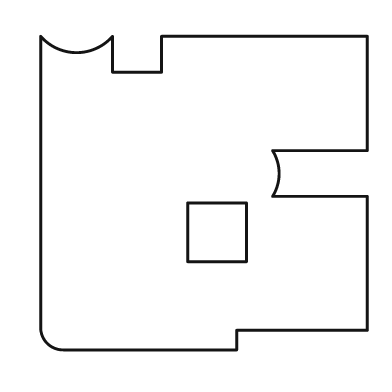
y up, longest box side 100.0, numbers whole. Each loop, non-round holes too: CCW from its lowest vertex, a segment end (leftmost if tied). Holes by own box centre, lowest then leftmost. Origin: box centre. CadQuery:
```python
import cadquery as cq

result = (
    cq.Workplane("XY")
    .moveTo(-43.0, -48.0)
    .lineTo(10.0, -48.0)
    .lineTo(10.0, -42.0)
    .lineTo(50.0, -42.0)
    .lineTo(50.0, -1.0)
    .lineTo(21.0, -1.0)
    .threePointArc((23.0, 6.0), (21.0, 13.0))
    .lineTo(50.0, 13.0)
    .lineTo(50.0, 48.0)
    .lineTo(-13.0, 48.0)
    .lineTo(-13.0, 37.0)
    .lineTo(-28.0, 37.0)
    .lineTo(-28.0, 48.0)
    .threePointArc((-39.0, 43.0), (-50.0, 48.0))
    .lineTo(-50.0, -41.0)
    .threePointArc((-48.0, -46.0), (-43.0, -48.0))
    .close()
    .moveTo(-5.0, -21.0)
    .lineTo(13.0, -21.0)
    .lineTo(13.0, -3.0)
    .lineTo(-5.0, -3.0)
    .close()
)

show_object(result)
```